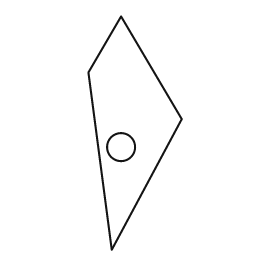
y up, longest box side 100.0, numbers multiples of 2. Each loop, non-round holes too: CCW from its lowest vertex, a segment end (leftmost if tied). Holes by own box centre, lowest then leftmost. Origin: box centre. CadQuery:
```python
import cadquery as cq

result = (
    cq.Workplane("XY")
    .moveTo(-10.0, -50.0)
    .lineTo(20.0, 6.0)
    .lineTo(-6.0, 50.0)
    .lineTo(-20.0, 26.0)
    .close()
    .moveTo(-6.0, -6.0)
    .circle(6.0)
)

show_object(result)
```